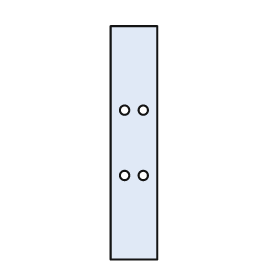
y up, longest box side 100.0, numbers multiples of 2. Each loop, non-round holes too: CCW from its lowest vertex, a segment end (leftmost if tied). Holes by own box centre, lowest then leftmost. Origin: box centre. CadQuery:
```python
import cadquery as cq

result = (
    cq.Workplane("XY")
    .moveTo(-10.0, -50.0)
    .lineTo(10.0, -50.0)
    .lineTo(10.0, 50.0)
    .lineTo(-10.0, 50.0)
    .close()
    .moveTo(-4.0, -14.0)
    .circle(2.0)
    .moveTo(4.0, -14.0)
    .circle(2.0)
    .moveTo(-4.0, 14.0)
    .circle(2.0)
    .moveTo(4.0, 14.0)
    .circle(2.0)
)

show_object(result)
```